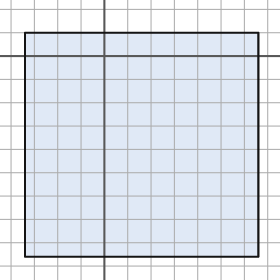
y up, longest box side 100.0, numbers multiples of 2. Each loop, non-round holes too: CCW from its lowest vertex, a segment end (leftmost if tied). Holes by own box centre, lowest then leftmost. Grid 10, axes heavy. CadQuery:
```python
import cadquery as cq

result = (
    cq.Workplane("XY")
    .moveTo(-34.0, -86.0)
    .lineTo(66.0, -86.0)
    .lineTo(66.0, 10.0)
    .lineTo(-34.0, 10.0)
    .close()
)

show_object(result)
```